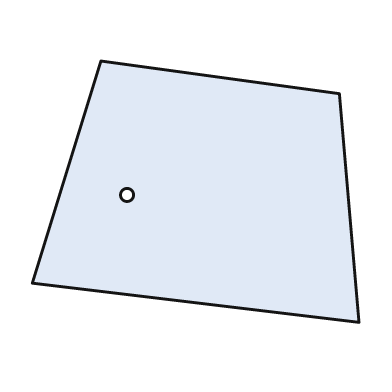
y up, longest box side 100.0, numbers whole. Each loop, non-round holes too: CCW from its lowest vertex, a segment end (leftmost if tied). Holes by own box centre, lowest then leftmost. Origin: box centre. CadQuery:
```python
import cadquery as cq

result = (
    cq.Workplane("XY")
    .moveTo(50.0, -40.0)
    .lineTo(44.0, 30.0)
    .lineTo(-29.0, 40.0)
    .lineTo(-50.0, -28.0)
    .close()
    .moveTo(-21.0, -1.0)
    .circle(2.0)
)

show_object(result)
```